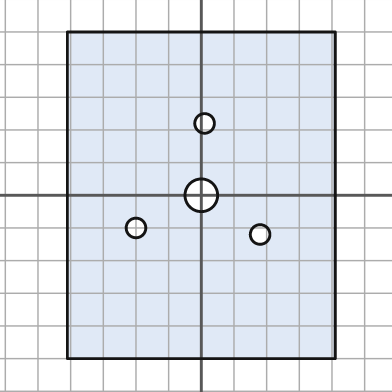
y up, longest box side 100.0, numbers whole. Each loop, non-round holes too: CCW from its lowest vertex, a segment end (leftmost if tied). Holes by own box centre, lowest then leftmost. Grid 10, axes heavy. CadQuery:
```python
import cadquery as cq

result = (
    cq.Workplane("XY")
    .moveTo(-41.0, -50.0)
    .lineTo(41.0, -50.0)
    .lineTo(41.0, 50.0)
    .lineTo(-41.0, 50.0)
    .close()
    .moveTo(18.0, -12.0)
    .circle(3.0)
    .moveTo(-20.0, -10.0)
    .circle(3.0)
    .moveTo(0.0, 0.0)
    .circle(5.0)
    .moveTo(1.0, 22.0)
    .circle(3.0)
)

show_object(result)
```